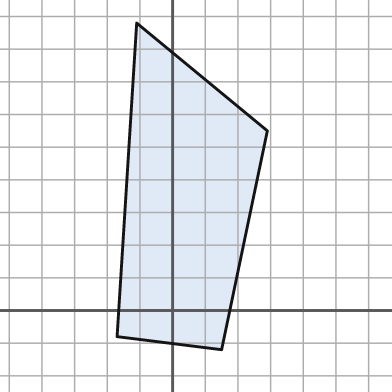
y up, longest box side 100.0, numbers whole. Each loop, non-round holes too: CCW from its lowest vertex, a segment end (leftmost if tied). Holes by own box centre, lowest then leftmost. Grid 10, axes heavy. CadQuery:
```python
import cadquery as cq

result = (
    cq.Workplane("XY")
    .moveTo(15.0, -12.0)
    .lineTo(29.0, 55.0)
    .lineTo(-11.0, 88.0)
    .lineTo(-17.0, -8.0)
    .close()
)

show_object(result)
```